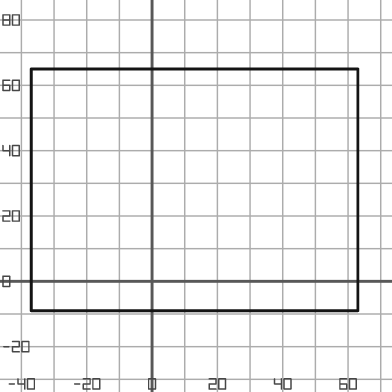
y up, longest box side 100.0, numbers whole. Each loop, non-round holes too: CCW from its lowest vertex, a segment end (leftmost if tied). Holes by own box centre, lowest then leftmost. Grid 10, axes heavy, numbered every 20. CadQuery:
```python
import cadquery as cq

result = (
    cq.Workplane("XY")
    .moveTo(-37.0, -9.0)
    .lineTo(63.0, -9.0)
    .lineTo(63.0, 65.0)
    .lineTo(-37.0, 65.0)
    .close()
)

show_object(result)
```